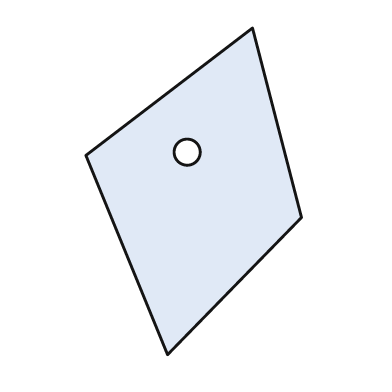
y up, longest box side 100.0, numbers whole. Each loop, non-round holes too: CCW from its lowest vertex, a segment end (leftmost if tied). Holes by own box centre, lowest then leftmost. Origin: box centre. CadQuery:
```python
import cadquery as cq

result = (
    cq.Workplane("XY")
    .moveTo(-8.0, -50.0)
    .lineTo(33.0, -8.0)
    .lineTo(18.0, 50.0)
    .lineTo(-33.0, 11.0)
    .close()
    .moveTo(-2.0, 12.0)
    .circle(4.0)
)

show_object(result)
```